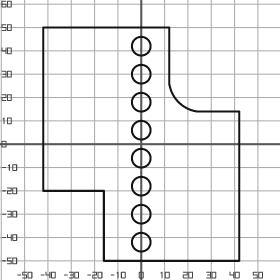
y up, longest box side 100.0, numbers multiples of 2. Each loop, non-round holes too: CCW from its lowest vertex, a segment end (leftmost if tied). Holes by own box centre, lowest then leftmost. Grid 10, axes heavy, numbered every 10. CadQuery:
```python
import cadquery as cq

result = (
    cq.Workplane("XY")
    .moveTo(-16.0, -50.0)
    .lineTo(42.0, -50.0)
    .lineTo(42.0, 14.0)
    .lineTo(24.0, 14.0)
    .threePointArc((16.0, 18.0), (12.0, 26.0))
    .lineTo(12.0, 50.0)
    .lineTo(-42.0, 50.0)
    .lineTo(-42.0, -20.0)
    .lineTo(-16.0, -20.0)
    .close()
    .moveTo(0.0, -42.0)
    .circle(4.0)
    .moveTo(0.0, -30.0)
    .circle(4.0)
    .moveTo(0.0, -18.0)
    .circle(4.0)
    .moveTo(0.0, -6.0)
    .circle(4.0)
    .moveTo(0.0, 6.0)
    .circle(4.0)
    .moveTo(0.0, 18.0)
    .circle(4.0)
    .moveTo(0.0, 30.0)
    .circle(4.0)
    .moveTo(0.0, 42.0)
    .circle(4.0)
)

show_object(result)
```